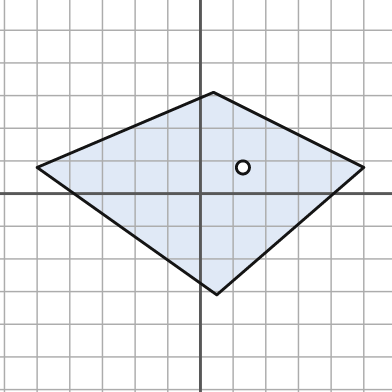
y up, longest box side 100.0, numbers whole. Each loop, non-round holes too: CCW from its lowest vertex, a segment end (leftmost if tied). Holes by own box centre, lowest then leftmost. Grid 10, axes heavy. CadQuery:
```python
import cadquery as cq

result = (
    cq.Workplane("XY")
    .moveTo(5.0, -31.0)
    .lineTo(50.0, 8.0)
    .lineTo(4.0, 31.0)
    .lineTo(-50.0, 8.0)
    .close()
    .moveTo(13.0, 8.0)
    .circle(2.0)
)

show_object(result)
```